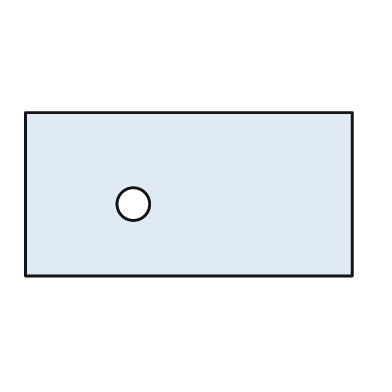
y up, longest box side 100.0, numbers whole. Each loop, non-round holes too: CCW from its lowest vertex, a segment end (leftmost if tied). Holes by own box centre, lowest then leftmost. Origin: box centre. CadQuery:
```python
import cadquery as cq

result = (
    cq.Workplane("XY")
    .moveTo(-50.0, -25.0)
    .lineTo(50.0, -25.0)
    .lineTo(50.0, 25.0)
    .lineTo(-50.0, 25.0)
    .close()
    .moveTo(-17.0, -3.0)
    .circle(5.0)
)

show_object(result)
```